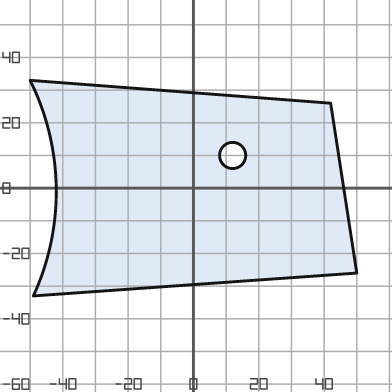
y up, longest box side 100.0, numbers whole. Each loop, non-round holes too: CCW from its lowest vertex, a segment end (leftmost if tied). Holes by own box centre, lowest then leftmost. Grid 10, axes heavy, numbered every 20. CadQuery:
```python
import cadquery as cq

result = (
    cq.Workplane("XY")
    .moveTo(-49.0, -33.0)
    .lineTo(50.0, -26.0)
    .lineTo(42.0, 26.0)
    .lineTo(-50.0, 33.0)
    .threePointArc((-42.0, 0.0), (-49.0, -33.0))
    .close()
    .moveTo(12.0, 10.0)
    .circle(4.0)
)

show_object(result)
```